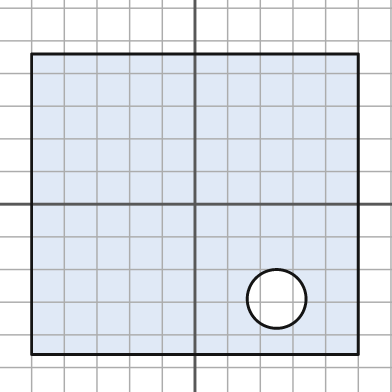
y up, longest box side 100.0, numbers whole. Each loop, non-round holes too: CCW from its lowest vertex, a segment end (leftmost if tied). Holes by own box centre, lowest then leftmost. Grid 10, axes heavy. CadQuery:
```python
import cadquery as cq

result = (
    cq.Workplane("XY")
    .moveTo(-50.0, -46.0)
    .lineTo(50.0, -46.0)
    .lineTo(50.0, 46.0)
    .lineTo(-50.0, 46.0)
    .close()
    .moveTo(25.0, -29.0)
    .circle(9.0)
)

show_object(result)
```